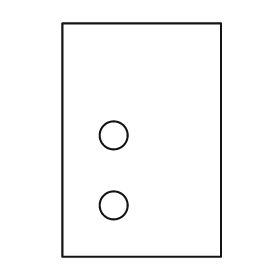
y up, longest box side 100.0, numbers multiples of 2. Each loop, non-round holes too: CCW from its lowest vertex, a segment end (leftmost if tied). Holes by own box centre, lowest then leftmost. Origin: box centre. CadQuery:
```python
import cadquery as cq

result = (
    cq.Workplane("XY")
    .moveTo(-34.0, -50.0)
    .lineTo(34.0, -50.0)
    .lineTo(34.0, 50.0)
    .lineTo(-34.0, 50.0)
    .close()
    .moveTo(-12.0, -28.0)
    .circle(6.0)
    .moveTo(-12.0, 2.0)
    .circle(6.0)
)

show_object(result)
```